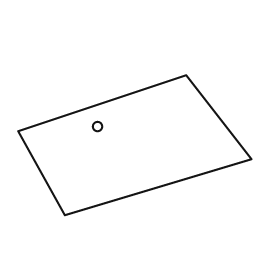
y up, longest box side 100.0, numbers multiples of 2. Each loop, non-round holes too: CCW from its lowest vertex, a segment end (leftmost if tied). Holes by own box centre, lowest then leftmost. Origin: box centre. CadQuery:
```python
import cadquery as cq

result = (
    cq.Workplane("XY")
    .moveTo(-30.0, -30.0)
    .lineTo(50.0, -6.0)
    .lineTo(22.0, 30.0)
    .lineTo(-50.0, 6.0)
    .close()
    .moveTo(-16.0, 8.0)
    .circle(2.0)
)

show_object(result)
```